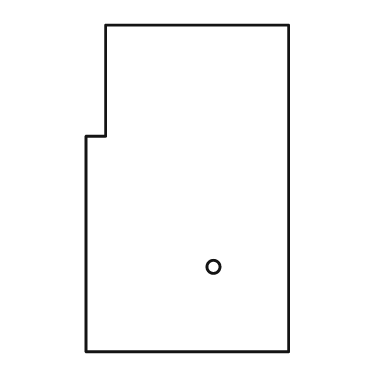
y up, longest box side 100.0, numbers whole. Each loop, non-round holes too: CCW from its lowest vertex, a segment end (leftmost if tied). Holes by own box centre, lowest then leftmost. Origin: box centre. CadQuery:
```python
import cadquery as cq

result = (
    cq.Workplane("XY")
    .moveTo(-31.0, -50.0)
    .lineTo(31.0, -50.0)
    .lineTo(31.0, 50.0)
    .lineTo(-25.0, 50.0)
    .lineTo(-25.0, 16.0)
    .lineTo(-31.0, 16.0)
    .close()
    .moveTo(8.0, -24.0)
    .circle(2.0)
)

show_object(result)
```